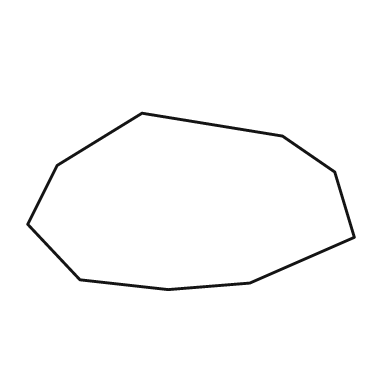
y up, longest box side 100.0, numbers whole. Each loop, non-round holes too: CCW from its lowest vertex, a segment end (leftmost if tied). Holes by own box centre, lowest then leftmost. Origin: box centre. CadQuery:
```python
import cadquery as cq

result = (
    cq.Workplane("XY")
    .moveTo(-7.0, -27.0)
    .lineTo(18.0, -25.0)
    .lineTo(50.0, -11.0)
    .lineTo(44.0, 9.0)
    .lineTo(28.0, 20.0)
    .lineTo(-15.0, 27.0)
    .lineTo(-41.0, 11.0)
    .lineTo(-50.0, -7.0)
    .lineTo(-34.0, -24.0)
    .close()
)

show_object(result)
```